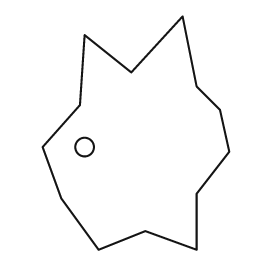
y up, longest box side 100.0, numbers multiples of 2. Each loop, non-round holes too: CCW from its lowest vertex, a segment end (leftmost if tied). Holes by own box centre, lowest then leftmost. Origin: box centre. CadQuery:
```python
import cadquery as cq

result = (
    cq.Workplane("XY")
    .moveTo(-16.0, -50.0)
    .lineTo(4.0, -42.0)
    .lineTo(26.0, -50.0)
    .lineTo(26.0, -26.0)
    .lineTo(40.0, -8.0)
    .lineTo(36.0, 10.0)
    .lineTo(26.0, 20.0)
    .lineTo(20.0, 50.0)
    .lineTo(-2.0, 26.0)
    .lineTo(-22.0, 42.0)
    .lineTo(-24.0, 12.0)
    .lineTo(-40.0, -6.0)
    .lineTo(-32.0, -28.0)
    .close()
    .moveTo(-22.0, -6.0)
    .circle(4.0)
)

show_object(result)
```